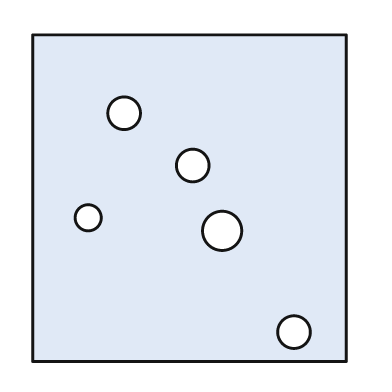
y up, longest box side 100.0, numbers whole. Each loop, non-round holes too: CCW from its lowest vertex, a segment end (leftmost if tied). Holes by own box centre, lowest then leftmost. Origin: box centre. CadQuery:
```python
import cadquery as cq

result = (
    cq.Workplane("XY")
    .moveTo(-48.0, -50.0)
    .lineTo(48.0, -50.0)
    .lineTo(48.0, 50.0)
    .lineTo(-48.0, 50.0)
    .close()
    .moveTo(32.0, -41.0)
    .circle(5.0)
    .moveTo(10.0, -10.0)
    .circle(6.0)
    .moveTo(-31.0, -6.0)
    .circle(4.0)
    .moveTo(1.0, 10.0)
    .circle(5.0)
    .moveTo(-20.0, 26.0)
    .circle(5.0)
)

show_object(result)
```